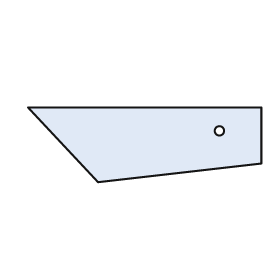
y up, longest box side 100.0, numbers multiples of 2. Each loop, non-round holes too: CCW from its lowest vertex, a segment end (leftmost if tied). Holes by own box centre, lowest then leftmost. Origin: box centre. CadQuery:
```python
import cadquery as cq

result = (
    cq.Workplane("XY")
    .moveTo(-20.0, -16.0)
    .lineTo(50.0, -8.0)
    .lineTo(50.0, 16.0)
    .lineTo(-50.0, 16.0)
    .close()
    .moveTo(32.0, 6.0)
    .circle(2.0)
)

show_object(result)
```